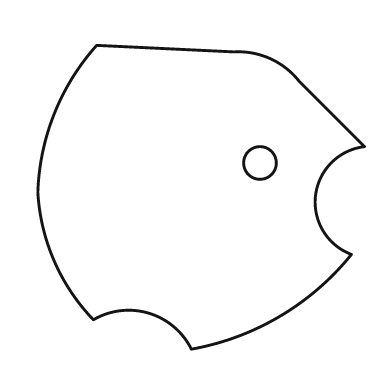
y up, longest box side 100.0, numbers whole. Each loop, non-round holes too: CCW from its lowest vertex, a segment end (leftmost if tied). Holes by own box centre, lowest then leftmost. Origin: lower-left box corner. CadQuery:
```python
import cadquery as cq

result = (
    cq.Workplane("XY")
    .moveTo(47.0, 0.0)
    .threePointArc((74.0, 10.0), (96.0, 29.0))
    .threePointArc((85.0, 47.0), (100.0, 62.0))
    .lineTo(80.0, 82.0)
    .threePointArc((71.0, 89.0), (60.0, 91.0))
    .lineTo(18.0, 93.0)
    .threePointArc((5.0, 72.0), (0.0, 48.0))
    .threePointArc((5.0, 27.0), (17.0, 9.0))
    .threePointArc((34.0, 11.0), (47.0, 0.0))
    .close()
    .moveTo(68.0, 57.0)
    .circle(5.0)
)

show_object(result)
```